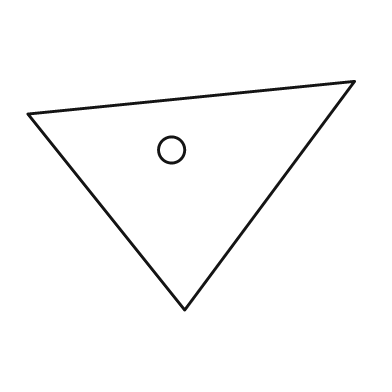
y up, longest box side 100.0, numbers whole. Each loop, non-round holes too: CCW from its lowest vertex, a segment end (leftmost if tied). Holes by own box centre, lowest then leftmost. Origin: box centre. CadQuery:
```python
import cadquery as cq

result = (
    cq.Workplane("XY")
    .moveTo(-2.0, -35.0)
    .lineTo(50.0, 35.0)
    .lineTo(-50.0, 25.0)
    .close()
    .moveTo(-6.0, 14.0)
    .circle(4.0)
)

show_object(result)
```